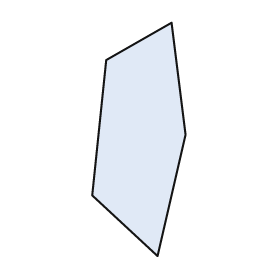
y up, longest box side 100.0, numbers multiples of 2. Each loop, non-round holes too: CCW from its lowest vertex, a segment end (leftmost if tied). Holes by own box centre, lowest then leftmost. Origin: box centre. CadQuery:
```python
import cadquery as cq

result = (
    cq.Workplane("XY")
    .moveTo(8.0, -50.0)
    .lineTo(20.0, 2.0)
    .lineTo(14.0, 50.0)
    .lineTo(-14.0, 34.0)
    .lineTo(-20.0, -24.0)
    .close()
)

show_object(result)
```